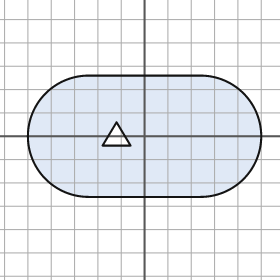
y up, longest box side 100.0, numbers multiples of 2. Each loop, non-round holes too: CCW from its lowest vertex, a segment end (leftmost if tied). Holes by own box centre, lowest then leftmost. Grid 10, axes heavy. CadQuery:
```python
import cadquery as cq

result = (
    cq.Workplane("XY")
    .moveTo(-24.0, -26.0)
    .lineTo(24.0, -26.0)
    .threePointArc((50.0, 0.0), (24.0, 26.0))
    .lineTo(-24.0, 26.0)
    .threePointArc((-50.0, 0.0), (-24.0, -26.0))
    .close()
    .moveTo(-18.0, -4.0)
    .lineTo(-6.0, -4.0)
    .lineTo(-12.0, 6.0)
    .close()
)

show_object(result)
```